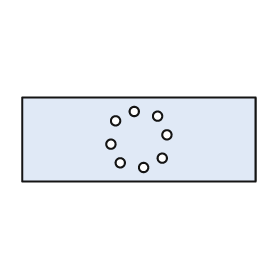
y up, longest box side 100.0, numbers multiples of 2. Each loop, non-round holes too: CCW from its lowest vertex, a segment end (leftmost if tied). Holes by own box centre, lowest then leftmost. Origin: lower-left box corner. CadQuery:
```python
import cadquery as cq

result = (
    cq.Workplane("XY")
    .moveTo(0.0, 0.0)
    .lineTo(100.0, 0.0)
    .lineTo(100.0, 36.0)
    .lineTo(0.0, 36.0)
    .close()
    .moveTo(52.0, 6.0)
    .circle(2.0)
    .moveTo(42.0, 8.0)
    .circle(2.0)
    .moveTo(60.0, 10.0)
    .circle(2.0)
    .moveTo(38.0, 16.0)
    .circle(2.0)
    .moveTo(62.0, 20.0)
    .circle(2.0)
    .moveTo(40.0, 26.0)
    .circle(2.0)
    .moveTo(58.0, 28.0)
    .circle(2.0)
    .moveTo(48.0, 30.0)
    .circle(2.0)
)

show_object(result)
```